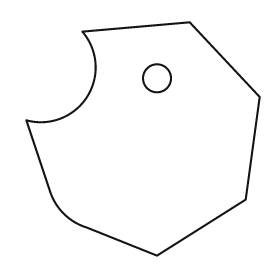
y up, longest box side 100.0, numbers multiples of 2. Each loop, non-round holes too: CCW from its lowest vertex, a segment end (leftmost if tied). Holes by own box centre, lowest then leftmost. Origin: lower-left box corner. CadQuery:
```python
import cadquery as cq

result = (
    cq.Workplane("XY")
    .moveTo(56.0, 0.0)
    .lineTo(94.0, 24.0)
    .lineTo(100.0, 68.0)
    .lineTo(70.0, 100.0)
    .lineTo(24.0, 96.0)
    .threePointArc((26.0, 68.0), (0.0, 58.0))
    .lineTo(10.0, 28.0)
    .threePointArc((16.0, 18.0), (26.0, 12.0))
    .close()
    .moveTo(56.0, 76.0)
    .circle(6.0)
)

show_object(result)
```